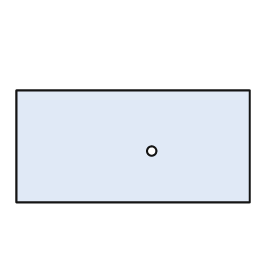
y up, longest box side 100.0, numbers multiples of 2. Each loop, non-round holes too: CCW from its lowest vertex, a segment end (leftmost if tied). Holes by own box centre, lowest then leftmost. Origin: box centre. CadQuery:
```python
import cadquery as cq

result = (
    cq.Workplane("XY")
    .moveTo(-50.0, -24.0)
    .lineTo(50.0, -24.0)
    .lineTo(50.0, 24.0)
    .lineTo(-50.0, 24.0)
    .close()
    .moveTo(8.0, -2.0)
    .circle(2.0)
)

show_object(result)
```